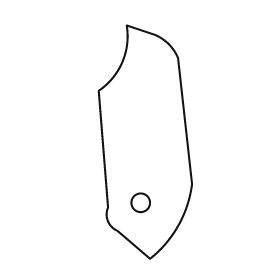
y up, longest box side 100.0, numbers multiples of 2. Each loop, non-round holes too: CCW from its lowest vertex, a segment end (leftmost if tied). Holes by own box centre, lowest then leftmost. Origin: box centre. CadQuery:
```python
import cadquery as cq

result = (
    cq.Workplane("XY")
    .moveTo(2.0, -50.0)
    .threePointArc((14.0, -36.0), (20.0, -18.0))
    .lineTo(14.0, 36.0)
    .threePointArc((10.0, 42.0), (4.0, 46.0))
    .lineTo(-8.0, 50.0)
    .threePointArc((-10.0, 34.0), (-20.0, 22.0))
    .lineTo(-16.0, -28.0)
    .threePointArc((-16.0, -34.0), (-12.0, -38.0))
    .close()
    .moveTo(-2.0, -26.0)
    .circle(4.0)
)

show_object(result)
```